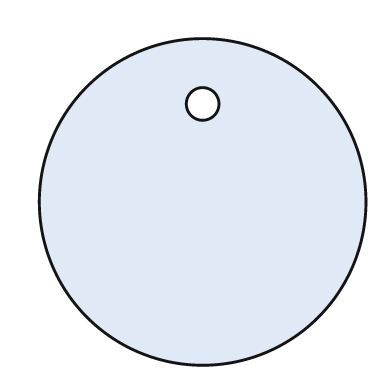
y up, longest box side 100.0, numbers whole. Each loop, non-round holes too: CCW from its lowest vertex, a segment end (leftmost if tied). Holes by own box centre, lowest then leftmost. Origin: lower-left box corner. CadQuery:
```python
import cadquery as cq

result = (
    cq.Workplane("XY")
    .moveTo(50.0, 50.0)
    .circle(50.0)
    .moveTo(50.0, 80.0)
    .circle(5.0)
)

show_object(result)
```